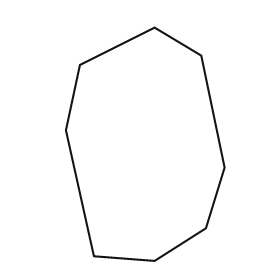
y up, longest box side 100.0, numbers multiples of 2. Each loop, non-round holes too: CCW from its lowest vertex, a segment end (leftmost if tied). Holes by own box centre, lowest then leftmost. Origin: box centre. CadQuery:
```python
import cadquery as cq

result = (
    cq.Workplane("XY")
    .moveTo(4.0, -50.0)
    .lineTo(26.0, -36.0)
    .lineTo(34.0, -10.0)
    .lineTo(24.0, 38.0)
    .lineTo(4.0, 50.0)
    .lineTo(-28.0, 34.0)
    .lineTo(-34.0, 6.0)
    .lineTo(-22.0, -48.0)
    .close()
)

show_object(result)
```